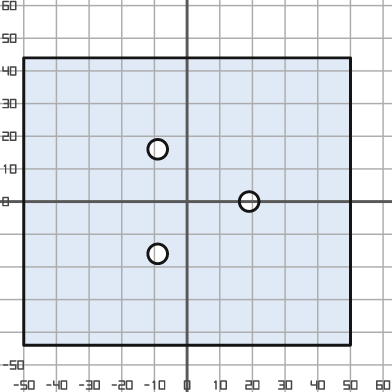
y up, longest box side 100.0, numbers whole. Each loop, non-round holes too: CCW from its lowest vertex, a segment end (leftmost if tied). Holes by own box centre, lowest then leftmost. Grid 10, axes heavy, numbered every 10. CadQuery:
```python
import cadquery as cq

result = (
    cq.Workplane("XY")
    .moveTo(-50.0, -44.0)
    .lineTo(50.0, -44.0)
    .lineTo(50.0, 44.0)
    .lineTo(-50.0, 44.0)
    .close()
    .moveTo(-9.0, -16.0)
    .circle(3.0)
    .moveTo(19.0, 0.0)
    .circle(3.0)
    .moveTo(-9.0, 16.0)
    .circle(3.0)
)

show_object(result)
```